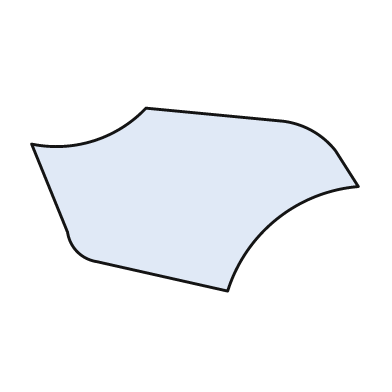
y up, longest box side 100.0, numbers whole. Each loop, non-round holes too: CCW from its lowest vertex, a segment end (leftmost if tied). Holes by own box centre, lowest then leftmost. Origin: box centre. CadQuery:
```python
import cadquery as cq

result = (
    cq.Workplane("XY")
    .moveTo(10.0, -28.0)
    .threePointArc((25.0, -6.0), (50.0, 4.0))
    .lineTo(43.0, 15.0)
    .threePointArc((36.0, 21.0), (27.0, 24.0))
    .lineTo(-15.0, 28.0)
    .threePointArc((-31.0, 18.0), (-50.0, 17.0))
    .lineTo(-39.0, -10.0)
    .threePointArc((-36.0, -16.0), (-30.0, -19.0))
    .close()
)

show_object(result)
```